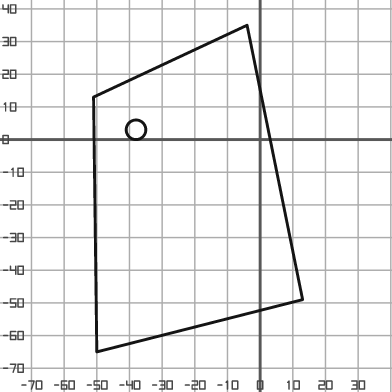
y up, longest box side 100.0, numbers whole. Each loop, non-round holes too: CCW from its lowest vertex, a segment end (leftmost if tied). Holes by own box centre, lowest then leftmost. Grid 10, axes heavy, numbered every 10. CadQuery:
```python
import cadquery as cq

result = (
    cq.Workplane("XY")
    .moveTo(-50.0, -65.0)
    .lineTo(13.0, -49.0)
    .lineTo(-4.0, 35.0)
    .lineTo(-51.0, 13.0)
    .close()
    .moveTo(-38.0, 3.0)
    .circle(3.0)
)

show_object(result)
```